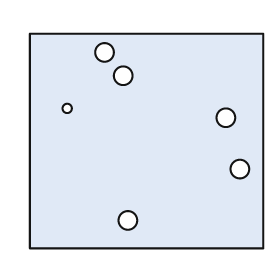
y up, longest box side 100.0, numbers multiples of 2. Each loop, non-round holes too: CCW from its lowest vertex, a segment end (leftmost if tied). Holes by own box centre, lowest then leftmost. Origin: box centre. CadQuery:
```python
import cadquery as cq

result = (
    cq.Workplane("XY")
    .moveTo(-50.0, -46.0)
    .lineTo(50.0, -46.0)
    .lineTo(50.0, 46.0)
    .lineTo(-50.0, 46.0)
    .close()
    .moveTo(-8.0, -34.0)
    .circle(4.0)
    .moveTo(40.0, -12.0)
    .circle(4.0)
    .moveTo(34.0, 10.0)
    .circle(4.0)
    .moveTo(-34.0, 14.0)
    .circle(2.0)
    .moveTo(-10.0, 28.0)
    .circle(4.0)
    .moveTo(-18.0, 38.0)
    .circle(4.0)
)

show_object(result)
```